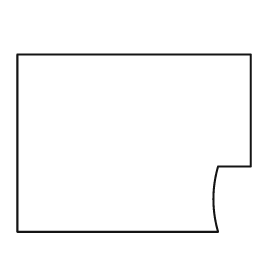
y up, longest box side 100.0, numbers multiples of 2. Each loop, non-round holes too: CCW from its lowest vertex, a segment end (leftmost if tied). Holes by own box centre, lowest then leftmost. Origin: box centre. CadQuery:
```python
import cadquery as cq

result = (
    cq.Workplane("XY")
    .moveTo(-50.0, -38.0)
    .lineTo(36.0, -38.0)
    .threePointArc((34.0, -24.0), (36.0, -10.0))
    .lineTo(50.0, -10.0)
    .lineTo(50.0, 38.0)
    .lineTo(-50.0, 38.0)
    .close()
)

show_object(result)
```